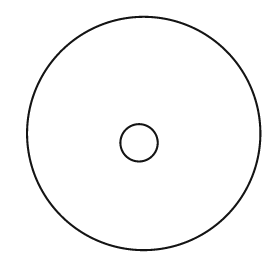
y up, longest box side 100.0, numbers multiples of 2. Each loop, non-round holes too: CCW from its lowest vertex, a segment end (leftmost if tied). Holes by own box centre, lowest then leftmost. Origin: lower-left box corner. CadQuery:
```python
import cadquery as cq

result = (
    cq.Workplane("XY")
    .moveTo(50.0, 50.0)
    .circle(50.0)
    .moveTo(48.0, 46.0)
    .circle(8.0)
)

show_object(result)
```